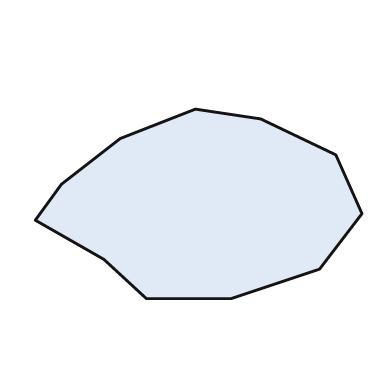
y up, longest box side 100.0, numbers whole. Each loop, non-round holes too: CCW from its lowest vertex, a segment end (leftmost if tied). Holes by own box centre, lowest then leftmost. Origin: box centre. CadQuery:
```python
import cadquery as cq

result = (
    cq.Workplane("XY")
    .moveTo(-16.0, -29.0)
    .lineTo(10.0, -29.0)
    .lineTo(37.0, -20.0)
    .lineTo(50.0, -3.0)
    .lineTo(42.0, 15.0)
    .lineTo(19.0, 26.0)
    .lineTo(-1.0, 29.0)
    .lineTo(-24.0, 20.0)
    .lineTo(-42.0, 6.0)
    .lineTo(-50.0, -5.0)
    .lineTo(-29.0, -17.0)
    .close()
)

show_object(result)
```